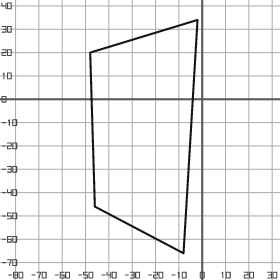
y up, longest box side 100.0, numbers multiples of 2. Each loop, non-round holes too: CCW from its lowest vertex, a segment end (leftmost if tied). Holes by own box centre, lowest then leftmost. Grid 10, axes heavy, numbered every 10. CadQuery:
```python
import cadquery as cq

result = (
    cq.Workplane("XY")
    .moveTo(-8.0, -66.0)
    .lineTo(-2.0, 34.0)
    .lineTo(-48.0, 20.0)
    .lineTo(-46.0, -46.0)
    .close()
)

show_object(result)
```